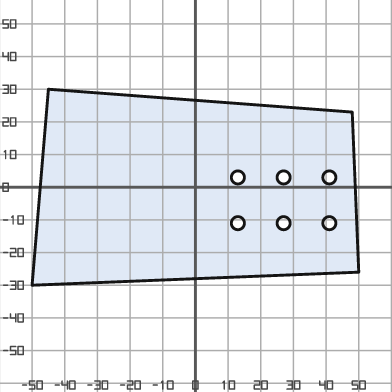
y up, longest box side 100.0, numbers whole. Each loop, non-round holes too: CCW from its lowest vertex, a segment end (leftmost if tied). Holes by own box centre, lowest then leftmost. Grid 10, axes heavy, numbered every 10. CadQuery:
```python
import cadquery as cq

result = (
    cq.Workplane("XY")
    .moveTo(-50.0, -30.0)
    .lineTo(50.0, -26.0)
    .lineTo(48.0, 23.0)
    .lineTo(-45.0, 30.0)
    .close()
    .moveTo(13.0, -11.0)
    .circle(2.0)
    .moveTo(27.0, -11.0)
    .circle(2.0)
    .moveTo(41.0, -11.0)
    .circle(2.0)
    .moveTo(13.0, 3.0)
    .circle(2.0)
    .moveTo(27.0, 3.0)
    .circle(2.0)
    .moveTo(41.0, 3.0)
    .circle(2.0)
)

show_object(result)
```